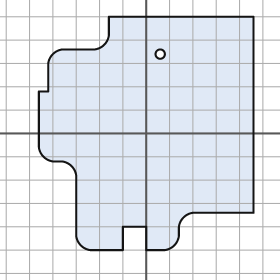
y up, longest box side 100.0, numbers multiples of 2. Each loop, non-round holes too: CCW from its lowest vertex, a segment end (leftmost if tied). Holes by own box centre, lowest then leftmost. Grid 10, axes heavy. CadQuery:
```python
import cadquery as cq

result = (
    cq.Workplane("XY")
    .moveTo(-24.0, -50.0)
    .lineTo(-10.0, -50.0)
    .lineTo(-10.0, -40.0)
    .lineTo(0.0, -40.0)
    .lineTo(0.0, -50.0)
    .lineTo(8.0, -50.0)
    .threePointArc((12.0, -48.0), (14.0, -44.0))
    .lineTo(14.0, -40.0)
    .threePointArc((16.0, -36.0), (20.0, -34.0))
    .lineTo(46.0, -34.0)
    .lineTo(46.0, 50.0)
    .lineTo(-16.0, 50.0)
    .lineTo(-16.0, 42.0)
    .threePointArc((-18.0, 38.0), (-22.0, 36.0))
    .lineTo(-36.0, 36.0)
    .threePointArc((-40.0, 34.0), (-42.0, 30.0))
    .lineTo(-42.0, 18.0)
    .lineTo(-46.0, 18.0)
    .lineTo(-46.0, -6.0)
    .threePointArc((-44.0, -10.0), (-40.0, -12.0))
    .lineTo(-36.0, -12.0)
    .threePointArc((-32.0, -14.0), (-30.0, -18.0))
    .lineTo(-30.0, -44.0)
    .threePointArc((-28.0, -48.0), (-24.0, -50.0))
    .close()
    .moveTo(6.0, 34.0)
    .circle(2.0)
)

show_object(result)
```